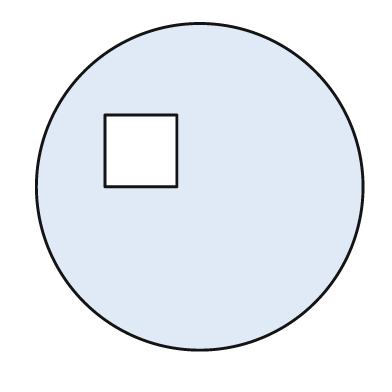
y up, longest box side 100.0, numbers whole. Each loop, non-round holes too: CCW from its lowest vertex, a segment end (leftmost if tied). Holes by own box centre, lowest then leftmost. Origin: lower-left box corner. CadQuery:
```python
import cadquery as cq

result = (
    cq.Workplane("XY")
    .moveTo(50.0, 50.0)
    .circle(50.0)
    .moveTo(21.0, 50.0)
    .lineTo(43.0, 50.0)
    .lineTo(43.0, 72.0)
    .lineTo(21.0, 72.0)
    .close()
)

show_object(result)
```